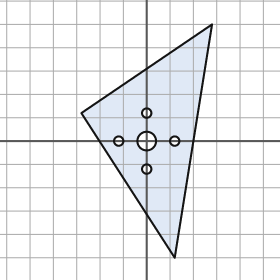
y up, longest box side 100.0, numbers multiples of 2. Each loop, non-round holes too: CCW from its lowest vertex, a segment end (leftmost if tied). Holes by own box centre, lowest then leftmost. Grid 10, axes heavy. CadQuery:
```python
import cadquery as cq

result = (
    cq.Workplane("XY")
    .moveTo(12.0, -50.0)
    .lineTo(28.0, 50.0)
    .lineTo(-28.0, 12.0)
    .close()
    .moveTo(0.0, -12.0)
    .circle(2.0)
    .moveTo(-12.0, 0.0)
    .circle(2.0)
    .moveTo(0.0, 0.0)
    .circle(4.0)
    .moveTo(12.0, 0.0)
    .circle(2.0)
    .moveTo(0.0, 12.0)
    .circle(2.0)
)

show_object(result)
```